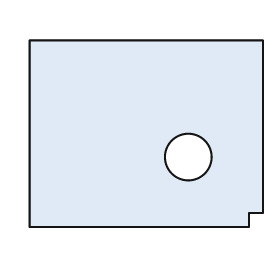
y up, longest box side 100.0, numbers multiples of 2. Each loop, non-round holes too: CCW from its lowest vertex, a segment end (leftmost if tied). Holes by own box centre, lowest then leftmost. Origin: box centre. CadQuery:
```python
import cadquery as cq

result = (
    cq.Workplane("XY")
    .moveTo(-50.0, -40.0)
    .lineTo(44.0, -40.0)
    .lineTo(44.0, -34.0)
    .lineTo(50.0, -34.0)
    .lineTo(50.0, 40.0)
    .lineTo(-50.0, 40.0)
    .close()
    .moveTo(18.0, -10.0)
    .circle(10.0)
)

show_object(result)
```